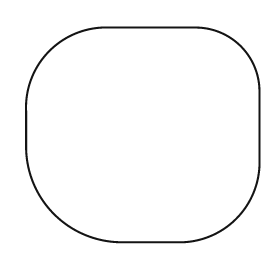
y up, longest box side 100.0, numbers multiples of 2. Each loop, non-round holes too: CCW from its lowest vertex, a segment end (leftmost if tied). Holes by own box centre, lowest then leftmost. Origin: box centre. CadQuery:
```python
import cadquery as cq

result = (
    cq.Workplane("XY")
    .moveTo(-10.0, -46.0)
    .lineTo(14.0, -46.0)
    .threePointArc((40.0, -36.0), (50.0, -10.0))
    .lineTo(50.0, 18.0)
    .threePointArc((42.0, 38.0), (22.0, 46.0))
    .lineTo(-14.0, 46.0)
    .threePointArc((-40.0, 36.0), (-50.0, 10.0))
    .lineTo(-50.0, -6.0)
    .threePointArc((-38.0, -34.0), (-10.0, -46.0))
    .close()
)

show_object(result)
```